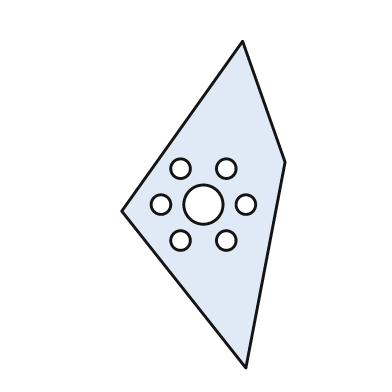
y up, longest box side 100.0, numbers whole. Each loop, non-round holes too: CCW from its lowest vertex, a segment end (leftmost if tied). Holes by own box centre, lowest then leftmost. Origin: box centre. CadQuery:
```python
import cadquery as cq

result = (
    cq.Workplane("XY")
    .moveTo(13.0, -50.0)
    .lineTo(25.0, 13.0)
    .lineTo(12.0, 50.0)
    .lineTo(-25.0, -2.0)
    .close()
    .moveTo(-7.0, -11.0)
    .circle(3.0)
    .moveTo(7.0, -11.0)
    .circle(3.0)
    .moveTo(-13.0, 0.0)
    .circle(3.0)
    .moveTo(0.0, 0.0)
    .circle(6.0)
    .moveTo(13.0, 0.0)
    .circle(3.0)
    .moveTo(-7.0, 11.0)
    .circle(3.0)
    .moveTo(7.0, 11.0)
    .circle(3.0)
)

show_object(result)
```